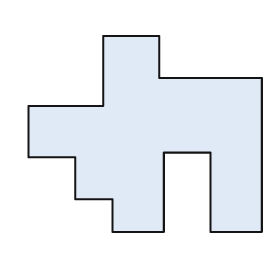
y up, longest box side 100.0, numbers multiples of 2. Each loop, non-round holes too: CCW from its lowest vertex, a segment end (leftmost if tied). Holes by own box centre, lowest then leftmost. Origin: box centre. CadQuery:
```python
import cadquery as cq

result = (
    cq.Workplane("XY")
    .moveTo(-14.0, -42.0)
    .lineTo(8.0, -42.0)
    .lineTo(8.0, -8.0)
    .lineTo(28.0, -8.0)
    .lineTo(28.0, -42.0)
    .lineTo(50.0, -42.0)
    .lineTo(50.0, 24.0)
    .lineTo(6.0, 24.0)
    .lineTo(6.0, 42.0)
    .lineTo(-18.0, 42.0)
    .lineTo(-18.0, 12.0)
    .lineTo(-50.0, 12.0)
    .lineTo(-50.0, -10.0)
    .lineTo(-30.0, -10.0)
    .lineTo(-30.0, -28.0)
    .lineTo(-14.0, -28.0)
    .close()
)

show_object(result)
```